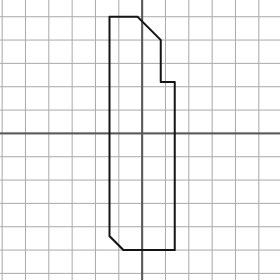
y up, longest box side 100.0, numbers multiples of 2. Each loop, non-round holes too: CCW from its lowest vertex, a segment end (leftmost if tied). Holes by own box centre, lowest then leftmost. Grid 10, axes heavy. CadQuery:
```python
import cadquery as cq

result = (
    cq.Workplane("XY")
    .moveTo(-8.0, -50.0)
    .lineTo(14.0, -50.0)
    .lineTo(14.0, 22.0)
    .lineTo(8.0, 22.0)
    .lineTo(8.0, 40.0)
    .lineTo(-2.0, 50.0)
    .lineTo(-14.0, 50.0)
    .lineTo(-14.0, -44.0)
    .close()
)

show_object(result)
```